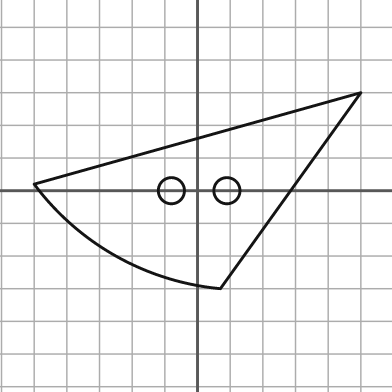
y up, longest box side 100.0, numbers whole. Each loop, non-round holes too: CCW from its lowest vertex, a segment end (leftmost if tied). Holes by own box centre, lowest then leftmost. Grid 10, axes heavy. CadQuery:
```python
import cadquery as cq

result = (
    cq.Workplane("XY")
    .moveTo(7.0, -30.0)
    .lineTo(50.0, 30.0)
    .lineTo(-50.0, 2.0)
    .threePointArc((-25.0, -20.0), (7.0, -30.0))
    .close()
    .moveTo(-8.0, 0.0)
    .circle(4.0)
    .moveTo(9.0, 0.0)
    .circle(4.0)
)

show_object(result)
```